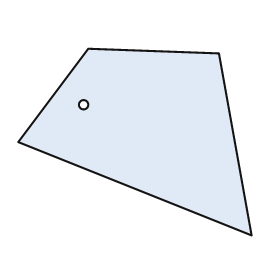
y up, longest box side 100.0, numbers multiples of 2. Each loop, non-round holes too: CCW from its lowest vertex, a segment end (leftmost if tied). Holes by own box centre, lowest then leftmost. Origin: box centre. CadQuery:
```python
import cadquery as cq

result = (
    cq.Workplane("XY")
    .moveTo(50.0, -40.0)
    .lineTo(36.0, 38.0)
    .lineTo(-20.0, 40.0)
    .lineTo(-50.0, 0.0)
    .close()
    .moveTo(-22.0, 16.0)
    .circle(2.0)
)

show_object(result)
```